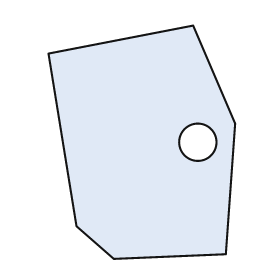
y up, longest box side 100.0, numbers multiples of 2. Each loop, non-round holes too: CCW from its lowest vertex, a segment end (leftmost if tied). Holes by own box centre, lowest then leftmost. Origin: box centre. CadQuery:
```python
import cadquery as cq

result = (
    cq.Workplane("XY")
    .moveTo(-12.0, -50.0)
    .lineTo(36.0, -48.0)
    .lineTo(40.0, 8.0)
    .lineTo(22.0, 50.0)
    .lineTo(-40.0, 38.0)
    .lineTo(-28.0, -36.0)
    .close()
    .moveTo(24.0, 0.0)
    .circle(8.0)
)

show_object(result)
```